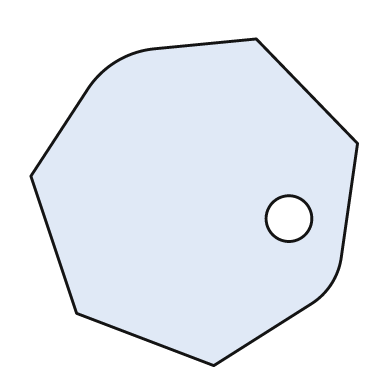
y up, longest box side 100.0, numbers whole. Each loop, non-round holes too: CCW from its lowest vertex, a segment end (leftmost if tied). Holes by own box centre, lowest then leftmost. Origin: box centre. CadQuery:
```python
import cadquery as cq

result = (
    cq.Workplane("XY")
    .moveTo(6.0, -50.0)
    .lineTo(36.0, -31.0)
    .threePointArc((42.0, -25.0), (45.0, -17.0))
    .lineTo(50.0, 18.0)
    .lineTo(19.0, 50.0)
    .lineTo(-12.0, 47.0)
    .threePointArc((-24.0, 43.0), (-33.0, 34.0))
    .lineTo(-50.0, 8.0)
    .lineTo(-36.0, -34.0)
    .close()
    .moveTo(29.0, -5.0)
    .circle(7.0)
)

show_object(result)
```